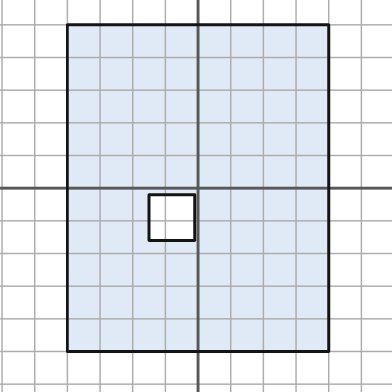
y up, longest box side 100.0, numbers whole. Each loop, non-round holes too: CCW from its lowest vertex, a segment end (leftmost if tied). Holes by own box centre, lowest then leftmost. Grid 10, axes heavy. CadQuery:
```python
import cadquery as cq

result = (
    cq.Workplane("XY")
    .moveTo(-40.0, -50.0)
    .lineTo(40.0, -50.0)
    .lineTo(40.0, 50.0)
    .lineTo(-40.0, 50.0)
    .close()
    .moveTo(-15.0, -16.0)
    .lineTo(-1.0, -16.0)
    .lineTo(-1.0, -2.0)
    .lineTo(-15.0, -2.0)
    .close()
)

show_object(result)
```